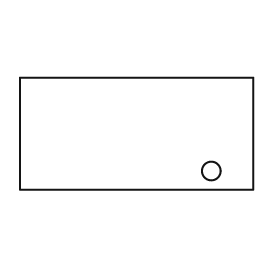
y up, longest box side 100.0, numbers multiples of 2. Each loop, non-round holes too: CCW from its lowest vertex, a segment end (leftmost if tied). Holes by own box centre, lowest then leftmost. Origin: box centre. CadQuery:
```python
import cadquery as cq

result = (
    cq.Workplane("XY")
    .moveTo(-50.0, -24.0)
    .lineTo(50.0, -24.0)
    .lineTo(50.0, 24.0)
    .lineTo(-50.0, 24.0)
    .close()
    .moveTo(32.0, -16.0)
    .circle(4.0)
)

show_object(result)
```